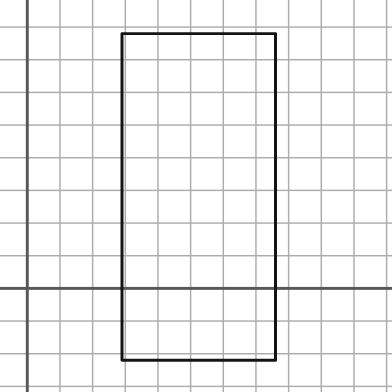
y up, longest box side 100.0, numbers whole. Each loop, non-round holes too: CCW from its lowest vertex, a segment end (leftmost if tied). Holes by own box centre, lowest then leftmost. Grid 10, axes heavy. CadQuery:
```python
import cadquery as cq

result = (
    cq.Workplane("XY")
    .moveTo(29.0, -22.0)
    .lineTo(76.0, -22.0)
    .lineTo(76.0, 78.0)
    .lineTo(29.0, 78.0)
    .close()
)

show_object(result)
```